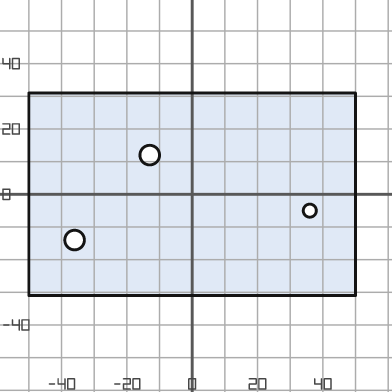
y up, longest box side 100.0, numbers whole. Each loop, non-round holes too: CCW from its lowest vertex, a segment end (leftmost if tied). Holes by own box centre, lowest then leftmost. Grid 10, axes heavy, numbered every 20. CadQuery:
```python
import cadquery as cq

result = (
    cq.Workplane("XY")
    .moveTo(-50.0, -31.0)
    .lineTo(50.0, -31.0)
    .lineTo(50.0, 31.0)
    .lineTo(-50.0, 31.0)
    .close()
    .moveTo(-36.0, -14.0)
    .circle(3.0)
    .moveTo(36.0, -5.0)
    .circle(2.0)
    .moveTo(-13.0, 12.0)
    .circle(3.0)
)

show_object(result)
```